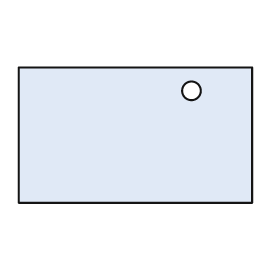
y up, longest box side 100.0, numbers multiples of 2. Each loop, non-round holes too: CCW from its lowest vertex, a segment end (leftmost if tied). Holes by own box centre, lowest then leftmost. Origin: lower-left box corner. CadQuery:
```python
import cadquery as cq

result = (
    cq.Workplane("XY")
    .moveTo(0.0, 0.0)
    .lineTo(100.0, 0.0)
    .lineTo(100.0, 58.0)
    .lineTo(0.0, 58.0)
    .close()
    .moveTo(74.0, 48.0)
    .circle(4.0)
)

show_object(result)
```